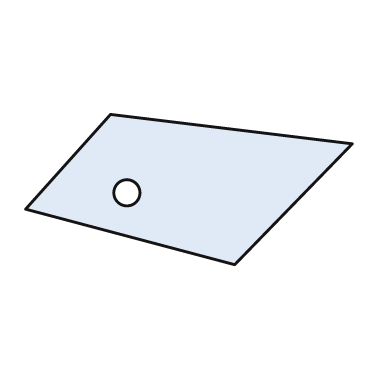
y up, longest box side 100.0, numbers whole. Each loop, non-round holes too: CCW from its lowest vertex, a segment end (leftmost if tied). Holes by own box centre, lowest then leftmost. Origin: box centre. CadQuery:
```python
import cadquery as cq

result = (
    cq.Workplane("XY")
    .moveTo(14.0, -23.0)
    .lineTo(50.0, 14.0)
    .lineTo(-24.0, 23.0)
    .lineTo(-50.0, -6.0)
    .close()
    .moveTo(-19.0, -1.0)
    .circle(4.0)
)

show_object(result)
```